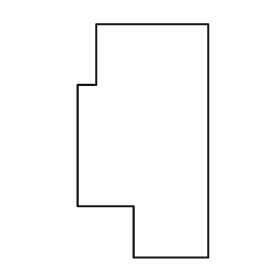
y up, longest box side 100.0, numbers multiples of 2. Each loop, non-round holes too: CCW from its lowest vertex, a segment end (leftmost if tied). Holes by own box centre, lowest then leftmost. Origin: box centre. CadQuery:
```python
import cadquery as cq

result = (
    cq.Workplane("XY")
    .moveTo(-4.0, -50.0)
    .lineTo(28.0, -50.0)
    .lineTo(28.0, 50.0)
    .lineTo(-20.0, 50.0)
    .lineTo(-20.0, 24.0)
    .lineTo(-28.0, 24.0)
    .lineTo(-28.0, -28.0)
    .lineTo(-4.0, -28.0)
    .close()
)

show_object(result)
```